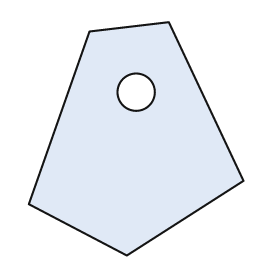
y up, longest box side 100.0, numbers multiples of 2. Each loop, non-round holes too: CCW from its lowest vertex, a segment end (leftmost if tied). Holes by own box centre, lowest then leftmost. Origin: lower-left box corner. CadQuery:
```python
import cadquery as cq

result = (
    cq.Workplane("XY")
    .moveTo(42.0, 0.0)
    .lineTo(92.0, 32.0)
    .lineTo(60.0, 100.0)
    .lineTo(26.0, 96.0)
    .lineTo(0.0, 22.0)
    .close()
    .moveTo(46.0, 70.0)
    .circle(8.0)
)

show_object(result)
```